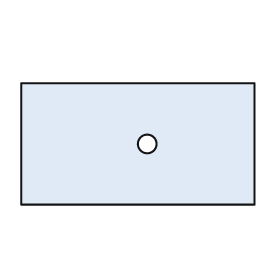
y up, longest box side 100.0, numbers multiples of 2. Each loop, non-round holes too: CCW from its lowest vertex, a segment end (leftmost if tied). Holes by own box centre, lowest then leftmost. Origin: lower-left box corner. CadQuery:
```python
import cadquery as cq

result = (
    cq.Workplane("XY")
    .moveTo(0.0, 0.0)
    .lineTo(100.0, 0.0)
    .lineTo(100.0, 52.0)
    .lineTo(0.0, 52.0)
    .close()
    .moveTo(54.0, 26.0)
    .circle(4.0)
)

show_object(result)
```